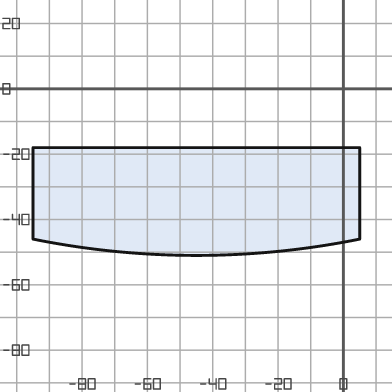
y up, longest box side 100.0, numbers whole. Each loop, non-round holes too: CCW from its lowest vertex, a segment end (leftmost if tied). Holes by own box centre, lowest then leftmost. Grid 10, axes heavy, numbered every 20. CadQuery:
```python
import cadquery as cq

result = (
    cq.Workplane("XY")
    .moveTo(-95.0, -46.0)
    .threePointArc((-45.0, -51.0), (5.0, -46.0))
    .lineTo(5.0, -18.0)
    .lineTo(-95.0, -18.0)
    .close()
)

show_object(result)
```